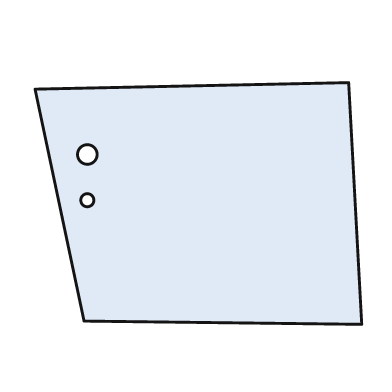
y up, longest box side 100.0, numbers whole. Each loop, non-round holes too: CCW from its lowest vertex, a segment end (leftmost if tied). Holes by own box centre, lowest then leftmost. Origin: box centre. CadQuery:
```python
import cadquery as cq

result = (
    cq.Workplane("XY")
    .moveTo(50.0, -37.0)
    .lineTo(46.0, 37.0)
    .lineTo(-50.0, 35.0)
    .lineTo(-35.0, -36.0)
    .close()
    .moveTo(-34.0, 1.0)
    .circle(2.0)
    .moveTo(-34.0, 15.0)
    .circle(3.0)
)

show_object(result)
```